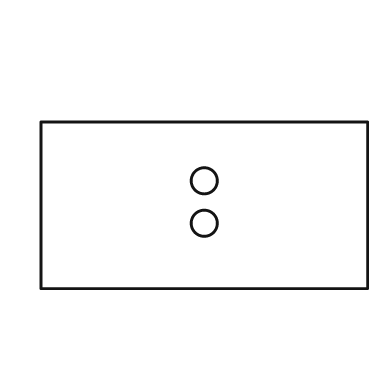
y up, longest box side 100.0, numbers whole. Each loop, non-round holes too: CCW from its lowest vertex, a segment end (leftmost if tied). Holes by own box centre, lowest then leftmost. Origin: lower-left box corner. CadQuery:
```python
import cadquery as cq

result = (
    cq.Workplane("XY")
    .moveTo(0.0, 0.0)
    .lineTo(100.0, 0.0)
    .lineTo(100.0, 51.0)
    .lineTo(0.0, 51.0)
    .close()
    .moveTo(50.0, 20.0)
    .circle(4.0)
    .moveTo(50.0, 33.0)
    .circle(4.0)
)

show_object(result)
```